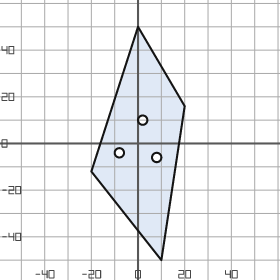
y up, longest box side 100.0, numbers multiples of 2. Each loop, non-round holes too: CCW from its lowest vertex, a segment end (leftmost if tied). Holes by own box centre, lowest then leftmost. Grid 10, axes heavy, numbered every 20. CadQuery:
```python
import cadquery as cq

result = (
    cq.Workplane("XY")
    .moveTo(10.0, -50.0)
    .lineTo(20.0, 16.0)
    .lineTo(0.0, 50.0)
    .lineTo(-20.0, -12.0)
    .close()
    .moveTo(8.0, -6.0)
    .circle(2.0)
    .moveTo(-8.0, -4.0)
    .circle(2.0)
    .moveTo(2.0, 10.0)
    .circle(2.0)
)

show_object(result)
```